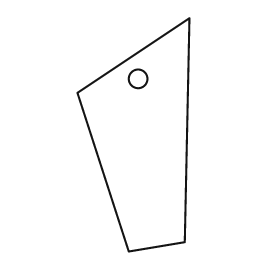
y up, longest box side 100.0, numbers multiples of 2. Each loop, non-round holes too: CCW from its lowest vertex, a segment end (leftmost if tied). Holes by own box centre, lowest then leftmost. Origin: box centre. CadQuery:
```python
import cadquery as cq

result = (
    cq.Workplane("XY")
    .moveTo(-2.0, -50.0)
    .lineTo(22.0, -46.0)
    .lineTo(24.0, 50.0)
    .lineTo(-24.0, 18.0)
    .close()
    .moveTo(2.0, 24.0)
    .circle(4.0)
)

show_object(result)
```